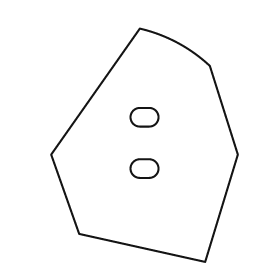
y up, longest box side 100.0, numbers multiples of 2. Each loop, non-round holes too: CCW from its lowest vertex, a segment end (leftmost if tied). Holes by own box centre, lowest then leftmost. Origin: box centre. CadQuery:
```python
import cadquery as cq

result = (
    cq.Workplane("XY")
    .moveTo(26.0, -50.0)
    .lineTo(40.0, -4.0)
    .lineTo(28.0, 34.0)
    .threePointArc((14.0, 44.0), (-2.0, 50.0))
    .lineTo(-40.0, -4.0)
    .lineTo(-28.0, -38.0)
    .close()
    .moveTo(-2.0, -14.0)
    .lineTo(2.0, -14.0)
    .threePointArc((6.0, -10.0), (2.0, -6.0))
    .lineTo(-2.0, -6.0)
    .threePointArc((-6.0, -10.0), (-2.0, -14.0))
    .close()
    .moveTo(-2.0, 8.0)
    .lineTo(2.0, 8.0)
    .threePointArc((6.0, 12.0), (2.0, 16.0))
    .lineTo(-2.0, 16.0)
    .threePointArc((-6.0, 12.0), (-2.0, 8.0))
    .close()
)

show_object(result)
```